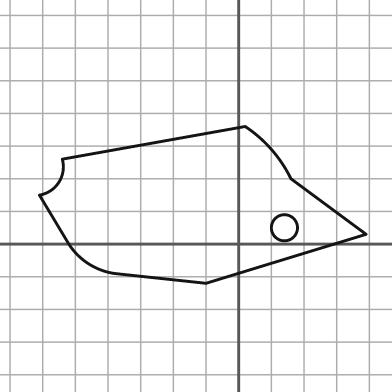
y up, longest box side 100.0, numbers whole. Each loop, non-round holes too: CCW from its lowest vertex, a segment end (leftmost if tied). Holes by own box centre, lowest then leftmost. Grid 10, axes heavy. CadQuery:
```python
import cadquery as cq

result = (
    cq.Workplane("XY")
    .moveTo(-10.0, -12.0)
    .lineTo(39.0, 3.0)
    .lineTo(16.0, 20.0)
    .threePointArc((10.0, 29.0), (2.0, 36.0))
    .lineTo(-54.0, 26.0)
    .threePointArc((-55.0, 19.0), (-61.0, 15.0))
    .lineTo(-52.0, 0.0)
    .threePointArc((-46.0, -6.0), (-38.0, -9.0))
    .close()
    .moveTo(14.0, 5.0)
    .circle(4.0)
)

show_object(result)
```